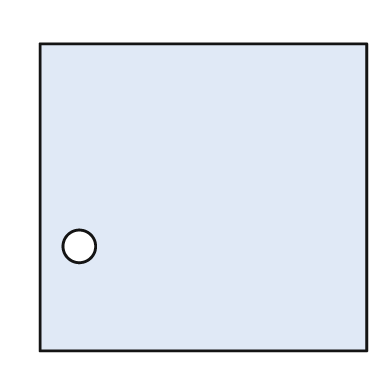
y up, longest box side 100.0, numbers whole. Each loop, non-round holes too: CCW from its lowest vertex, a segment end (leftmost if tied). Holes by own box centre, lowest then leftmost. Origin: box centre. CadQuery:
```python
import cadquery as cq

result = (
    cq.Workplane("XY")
    .moveTo(-50.0, -47.0)
    .lineTo(50.0, -47.0)
    .lineTo(50.0, 47.0)
    .lineTo(-50.0, 47.0)
    .close()
    .moveTo(-38.0, -15.0)
    .circle(5.0)
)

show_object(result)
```